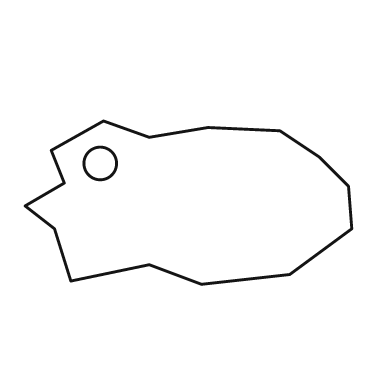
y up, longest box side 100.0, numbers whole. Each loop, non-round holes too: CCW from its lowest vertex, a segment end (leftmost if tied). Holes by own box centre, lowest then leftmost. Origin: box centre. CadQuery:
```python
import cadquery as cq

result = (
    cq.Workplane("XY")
    .moveTo(4.0, -25.0)
    .lineTo(31.0, -22.0)
    .lineTo(50.0, -8.0)
    .lineTo(49.0, 5.0)
    .lineTo(40.0, 14.0)
    .lineTo(28.0, 22.0)
    .lineTo(6.0, 23.0)
    .lineTo(-12.0, 20.0)
    .lineTo(-26.0, 25.0)
    .lineTo(-42.0, 16.0)
    .lineTo(-38.0, 6.0)
    .lineTo(-50.0, -1.0)
    .lineTo(-41.0, -8.0)
    .lineTo(-36.0, -24.0)
    .lineTo(-12.0, -19.0)
    .close()
    .moveTo(-27.0, 12.0)
    .circle(5.0)
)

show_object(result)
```